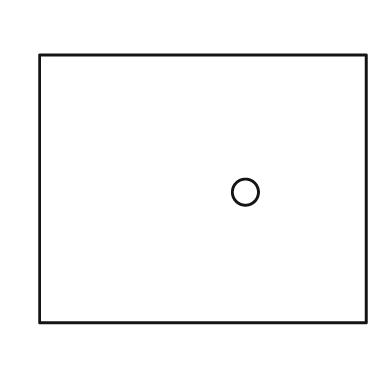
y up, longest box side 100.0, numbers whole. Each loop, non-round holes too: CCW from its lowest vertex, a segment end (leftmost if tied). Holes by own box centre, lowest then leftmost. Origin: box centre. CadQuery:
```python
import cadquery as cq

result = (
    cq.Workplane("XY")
    .moveTo(-50.0, -41.0)
    .lineTo(50.0, -41.0)
    .lineTo(50.0, 41.0)
    .lineTo(-50.0, 41.0)
    .close()
    .moveTo(13.0, -1.0)
    .circle(4.0)
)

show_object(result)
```